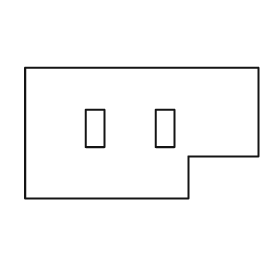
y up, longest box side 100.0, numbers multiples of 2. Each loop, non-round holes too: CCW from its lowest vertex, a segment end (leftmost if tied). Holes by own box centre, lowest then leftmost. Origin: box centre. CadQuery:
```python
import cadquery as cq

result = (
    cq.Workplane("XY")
    .moveTo(-50.0, -28.0)
    .lineTo(20.0, -28.0)
    .lineTo(20.0, -10.0)
    .lineTo(50.0, -10.0)
    .lineTo(50.0, 28.0)
    .lineTo(-50.0, 28.0)
    .close()
    .moveTo(-24.0, -6.0)
    .lineTo(-16.0, -6.0)
    .lineTo(-16.0, 10.0)
    .lineTo(-24.0, 10.0)
    .close()
    .moveTo(6.0, -6.0)
    .lineTo(14.0, -6.0)
    .lineTo(14.0, 10.0)
    .lineTo(6.0, 10.0)
    .close()
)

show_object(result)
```